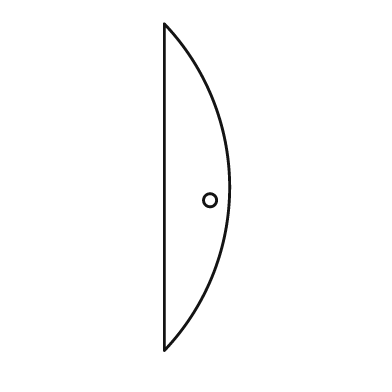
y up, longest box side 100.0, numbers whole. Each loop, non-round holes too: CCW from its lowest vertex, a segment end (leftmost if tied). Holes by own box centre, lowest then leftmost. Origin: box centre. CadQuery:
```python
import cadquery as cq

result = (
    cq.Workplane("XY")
    .moveTo(-10.0, -50.0)
    .threePointArc((10.0, 0.0), (-10.0, 50.0))
    .close()
    .moveTo(4.0, -4.0)
    .circle(2.0)
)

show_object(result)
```